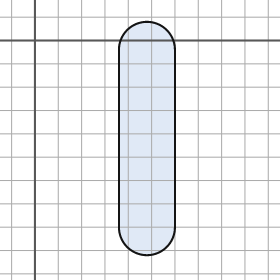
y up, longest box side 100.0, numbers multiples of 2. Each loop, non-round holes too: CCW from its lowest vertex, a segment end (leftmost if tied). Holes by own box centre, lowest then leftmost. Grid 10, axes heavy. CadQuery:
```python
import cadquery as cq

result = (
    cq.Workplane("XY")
    .moveTo(36.0, -80.0)
    .threePointArc((48.0, -92.0), (60.0, -80.0))
    .lineTo(60.0, -4.0)
    .threePointArc((48.0, 8.0), (36.0, -4.0))
    .close()
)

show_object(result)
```